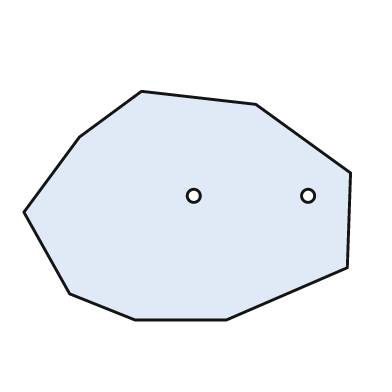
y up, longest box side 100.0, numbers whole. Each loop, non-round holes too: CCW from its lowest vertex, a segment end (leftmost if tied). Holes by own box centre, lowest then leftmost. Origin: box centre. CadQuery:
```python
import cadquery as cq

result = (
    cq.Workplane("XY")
    .moveTo(-16.0, -35.0)
    .lineTo(12.0, -35.0)
    .lineTo(49.0, -19.0)
    .lineTo(50.0, 10.0)
    .lineTo(21.0, 31.0)
    .lineTo(-14.0, 35.0)
    .lineTo(-33.0, 21.0)
    .lineTo(-50.0, -2.0)
    .lineTo(-36.0, -27.0)
    .close()
    .moveTo(2.0, 3.0)
    .circle(2.0)
    .moveTo(37.0, 3.0)
    .circle(2.0)
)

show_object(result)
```